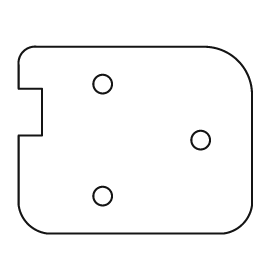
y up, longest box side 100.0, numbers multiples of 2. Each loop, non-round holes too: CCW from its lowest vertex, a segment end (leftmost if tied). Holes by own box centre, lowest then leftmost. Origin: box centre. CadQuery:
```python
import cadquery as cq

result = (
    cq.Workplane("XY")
    .moveTo(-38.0, -40.0)
    .lineTo(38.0, -40.0)
    .threePointArc((46.0, -36.0), (50.0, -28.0))
    .lineTo(50.0, 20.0)
    .threePointArc((44.0, 34.0), (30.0, 40.0))
    .lineTo(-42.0, 40.0)
    .threePointArc((-48.0, 38.0), (-50.0, 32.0))
    .lineTo(-50.0, 22.0)
    .lineTo(-40.0, 22.0)
    .lineTo(-40.0, 2.0)
    .lineTo(-50.0, 2.0)
    .lineTo(-50.0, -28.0)
    .threePointArc((-46.0, -36.0), (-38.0, -40.0))
    .close()
    .moveTo(-14.0, -24.0)
    .circle(4.0)
    .moveTo(28.0, 0.0)
    .circle(4.0)
    .moveTo(-14.0, 24.0)
    .circle(4.0)
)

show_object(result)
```